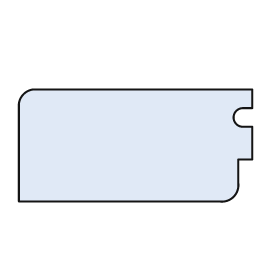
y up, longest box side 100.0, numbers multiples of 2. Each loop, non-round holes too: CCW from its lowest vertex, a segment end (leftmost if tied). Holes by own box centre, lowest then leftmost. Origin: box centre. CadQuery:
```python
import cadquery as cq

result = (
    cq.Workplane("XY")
    .moveTo(-50.0, -24.0)
    .lineTo(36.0, -24.0)
    .threePointArc((42.0, -22.0), (44.0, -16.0))
    .lineTo(44.0, -6.0)
    .lineTo(50.0, -6.0)
    .lineTo(50.0, 8.0)
    .lineTo(46.0, 8.0)
    .threePointArc((42.0, 12.0), (46.0, 16.0))
    .lineTo(50.0, 16.0)
    .lineTo(50.0, 24.0)
    .lineTo(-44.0, 24.0)
    .threePointArc((-48.0, 22.0), (-50.0, 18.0))
    .close()
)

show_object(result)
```